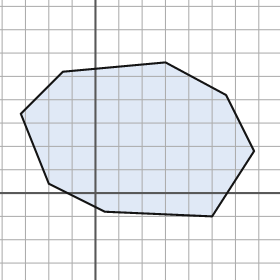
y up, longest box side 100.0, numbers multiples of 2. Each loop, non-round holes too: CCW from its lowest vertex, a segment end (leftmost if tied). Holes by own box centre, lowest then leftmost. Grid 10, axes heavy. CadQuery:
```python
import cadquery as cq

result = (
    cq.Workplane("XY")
    .moveTo(50.0, -10.0)
    .lineTo(68.0, 18.0)
    .lineTo(56.0, 42.0)
    .lineTo(30.0, 56.0)
    .lineTo(-14.0, 52.0)
    .lineTo(-32.0, 34.0)
    .lineTo(-20.0, 4.0)
    .lineTo(4.0, -8.0)
    .close()
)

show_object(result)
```